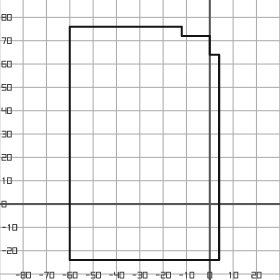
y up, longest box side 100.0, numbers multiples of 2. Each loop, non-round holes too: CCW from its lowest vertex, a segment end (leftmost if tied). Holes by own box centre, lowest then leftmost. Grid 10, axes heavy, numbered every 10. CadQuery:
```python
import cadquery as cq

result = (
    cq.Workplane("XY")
    .moveTo(-60.0, -24.0)
    .lineTo(4.0, -24.0)
    .lineTo(4.0, 64.0)
    .lineTo(0.0, 64.0)
    .lineTo(0.0, 72.0)
    .lineTo(-12.0, 72.0)
    .lineTo(-12.0, 76.0)
    .lineTo(-60.0, 76.0)
    .close()
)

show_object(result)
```